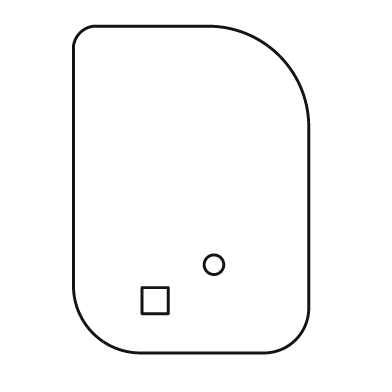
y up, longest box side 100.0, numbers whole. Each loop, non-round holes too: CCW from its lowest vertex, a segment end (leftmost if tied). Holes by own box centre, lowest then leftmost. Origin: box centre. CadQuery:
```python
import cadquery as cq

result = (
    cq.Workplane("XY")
    .moveTo(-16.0, -50.0)
    .lineTo(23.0, -50.0)
    .threePointArc((32.0, -46.0), (36.0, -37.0))
    .lineTo(36.0, 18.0)
    .threePointArc((27.0, 41.0), (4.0, 50.0))
    .lineTo(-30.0, 50.0)
    .threePointArc((-34.0, 48.0), (-36.0, 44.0))
    .lineTo(-36.0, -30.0)
    .threePointArc((-30.0, -44.0), (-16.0, -50.0))
    .close()
    .moveTo(-15.0, -38.0)
    .lineTo(-7.0, -38.0)
    .lineTo(-7.0, -30.0)
    .lineTo(-15.0, -30.0)
    .close()
    .moveTo(7.0, -23.0)
    .circle(3.0)
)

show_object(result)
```